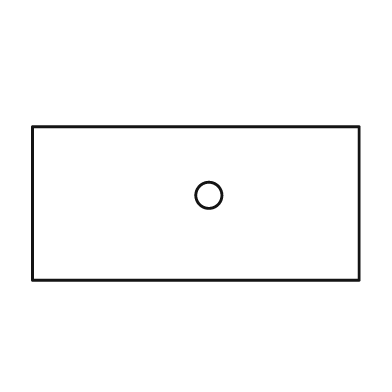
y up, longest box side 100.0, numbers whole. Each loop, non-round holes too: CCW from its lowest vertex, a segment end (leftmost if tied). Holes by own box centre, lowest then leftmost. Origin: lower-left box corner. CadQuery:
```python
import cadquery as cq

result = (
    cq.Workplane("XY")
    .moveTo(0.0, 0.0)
    .lineTo(100.0, 0.0)
    .lineTo(100.0, 47.0)
    .lineTo(0.0, 47.0)
    .close()
    .moveTo(54.0, 26.0)
    .circle(4.0)
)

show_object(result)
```